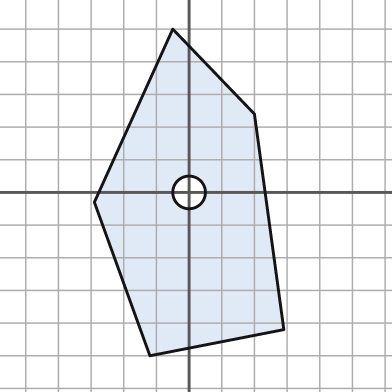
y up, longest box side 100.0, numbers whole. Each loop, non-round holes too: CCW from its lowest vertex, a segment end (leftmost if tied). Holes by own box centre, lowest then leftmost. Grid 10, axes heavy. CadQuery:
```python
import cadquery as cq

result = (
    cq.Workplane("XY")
    .moveTo(-12.0, -50.0)
    .lineTo(29.0, -42.0)
    .lineTo(20.0, 24.0)
    .lineTo(-5.0, 50.0)
    .lineTo(-29.0, -3.0)
    .close()
    .moveTo(0.0, 0.0)
    .circle(5.0)
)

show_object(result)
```